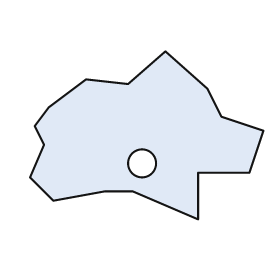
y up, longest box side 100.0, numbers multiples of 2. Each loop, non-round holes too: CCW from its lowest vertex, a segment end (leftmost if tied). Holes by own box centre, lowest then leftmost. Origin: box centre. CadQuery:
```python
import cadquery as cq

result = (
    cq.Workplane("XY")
    .moveTo(22.0, -36.0)
    .lineTo(22.0, -16.0)
    .lineTo(44.0, -16.0)
    .lineTo(50.0, 2.0)
    .lineTo(32.0, 8.0)
    .lineTo(26.0, 20.0)
    .lineTo(8.0, 36.0)
    .lineTo(-8.0, 22.0)
    .lineTo(-26.0, 24.0)
    .lineTo(-42.0, 12.0)
    .lineTo(-48.0, 4.0)
    .lineTo(-44.0, -4.0)
    .lineTo(-50.0, -18.0)
    .lineTo(-40.0, -28.0)
    .lineTo(-18.0, -24.0)
    .lineTo(-6.0, -24.0)
    .close()
    .moveTo(-2.0, -12.0)
    .circle(6.0)
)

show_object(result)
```